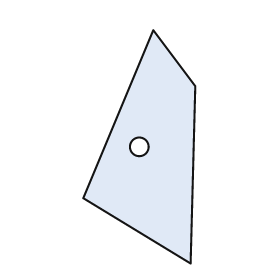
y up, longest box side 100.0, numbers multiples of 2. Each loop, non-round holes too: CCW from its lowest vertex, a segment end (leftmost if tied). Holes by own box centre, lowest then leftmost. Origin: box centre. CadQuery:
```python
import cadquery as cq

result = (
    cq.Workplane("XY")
    .moveTo(22.0, -50.0)
    .lineTo(24.0, 26.0)
    .lineTo(6.0, 50.0)
    .lineTo(-24.0, -22.0)
    .close()
    .moveTo(0.0, 0.0)
    .circle(4.0)
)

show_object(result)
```